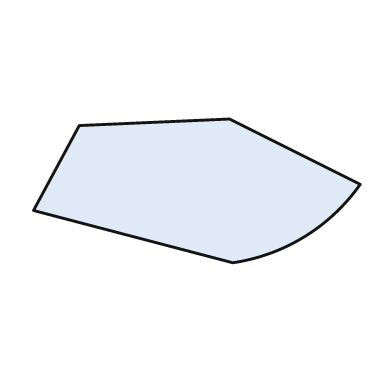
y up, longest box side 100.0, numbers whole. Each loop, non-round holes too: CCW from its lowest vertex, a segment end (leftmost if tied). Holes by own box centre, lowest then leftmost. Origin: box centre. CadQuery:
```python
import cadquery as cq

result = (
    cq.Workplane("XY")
    .moveTo(11.0, -22.0)
    .threePointArc((33.0, -14.0), (50.0, 2.0))
    .lineTo(10.0, 22.0)
    .lineTo(-36.0, 20.0)
    .lineTo(-50.0, -6.0)
    .close()
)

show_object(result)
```